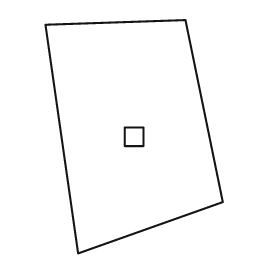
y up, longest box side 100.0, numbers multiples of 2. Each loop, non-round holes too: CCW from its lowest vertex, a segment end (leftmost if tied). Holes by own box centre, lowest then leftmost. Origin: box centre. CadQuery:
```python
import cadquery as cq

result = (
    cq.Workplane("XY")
    .moveTo(-24.0, -50.0)
    .lineTo(38.0, -28.0)
    .lineTo(22.0, 50.0)
    .lineTo(-38.0, 48.0)
    .close()
    .moveTo(-4.0, -4.0)
    .lineTo(4.0, -4.0)
    .lineTo(4.0, 4.0)
    .lineTo(-4.0, 4.0)
    .close()
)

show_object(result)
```